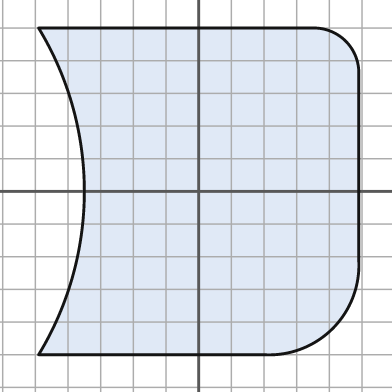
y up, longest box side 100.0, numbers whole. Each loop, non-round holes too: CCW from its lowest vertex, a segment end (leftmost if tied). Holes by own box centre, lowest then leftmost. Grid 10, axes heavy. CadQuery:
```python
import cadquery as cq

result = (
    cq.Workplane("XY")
    .moveTo(-49.0, -50.0)
    .lineTo(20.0, -50.0)
    .threePointArc((41.0, -42.0), (49.0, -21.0))
    .lineTo(49.0, 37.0)
    .threePointArc((45.0, 46.0), (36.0, 50.0))
    .lineTo(-49.0, 50.0)
    .threePointArc((-35.0, 0.0), (-49.0, -50.0))
    .close()
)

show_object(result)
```